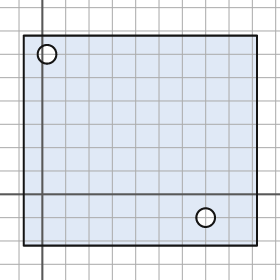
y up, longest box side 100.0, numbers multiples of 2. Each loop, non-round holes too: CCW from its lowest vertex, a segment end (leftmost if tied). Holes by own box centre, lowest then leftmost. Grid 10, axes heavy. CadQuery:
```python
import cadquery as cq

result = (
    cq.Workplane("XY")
    .moveTo(-8.0, -22.0)
    .lineTo(92.0, -22.0)
    .lineTo(92.0, 68.0)
    .lineTo(-8.0, 68.0)
    .close()
    .moveTo(70.0, -10.0)
    .circle(4.0)
    .moveTo(2.0, 60.0)
    .circle(4.0)
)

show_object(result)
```